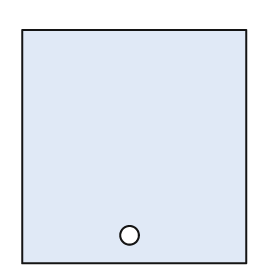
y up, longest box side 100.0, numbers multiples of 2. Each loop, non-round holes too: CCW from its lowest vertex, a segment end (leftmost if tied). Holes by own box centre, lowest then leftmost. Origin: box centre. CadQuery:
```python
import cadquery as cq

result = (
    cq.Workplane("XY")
    .moveTo(-48.0, -50.0)
    .lineTo(48.0, -50.0)
    .lineTo(48.0, 50.0)
    .lineTo(-48.0, 50.0)
    .close()
    .moveTo(-2.0, -38.0)
    .circle(4.0)
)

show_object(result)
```